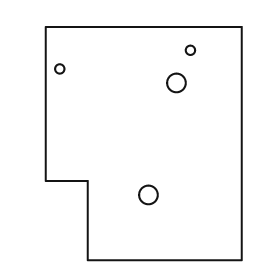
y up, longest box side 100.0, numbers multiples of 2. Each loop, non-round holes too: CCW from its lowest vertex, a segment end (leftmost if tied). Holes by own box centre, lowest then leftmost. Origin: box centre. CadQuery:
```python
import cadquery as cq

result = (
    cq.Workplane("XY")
    .moveTo(-24.0, -50.0)
    .lineTo(42.0, -50.0)
    .lineTo(42.0, 50.0)
    .lineTo(-42.0, 50.0)
    .lineTo(-42.0, -16.0)
    .lineTo(-24.0, -16.0)
    .close()
    .moveTo(2.0, -22.0)
    .circle(4.0)
    .moveTo(14.0, 26.0)
    .circle(4.0)
    .moveTo(-36.0, 32.0)
    .circle(2.0)
    .moveTo(20.0, 40.0)
    .circle(2.0)
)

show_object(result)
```